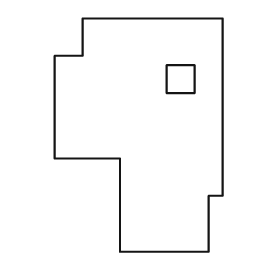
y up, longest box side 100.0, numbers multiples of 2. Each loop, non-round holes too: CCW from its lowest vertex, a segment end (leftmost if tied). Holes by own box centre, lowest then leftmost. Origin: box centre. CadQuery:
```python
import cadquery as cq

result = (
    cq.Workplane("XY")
    .moveTo(-8.0, -50.0)
    .lineTo(30.0, -50.0)
    .lineTo(30.0, -26.0)
    .lineTo(36.0, -26.0)
    .lineTo(36.0, 50.0)
    .lineTo(-24.0, 50.0)
    .lineTo(-24.0, 34.0)
    .lineTo(-36.0, 34.0)
    .lineTo(-36.0, -10.0)
    .lineTo(-8.0, -10.0)
    .close()
    .moveTo(12.0, 18.0)
    .lineTo(24.0, 18.0)
    .lineTo(24.0, 30.0)
    .lineTo(12.0, 30.0)
    .close()
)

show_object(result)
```